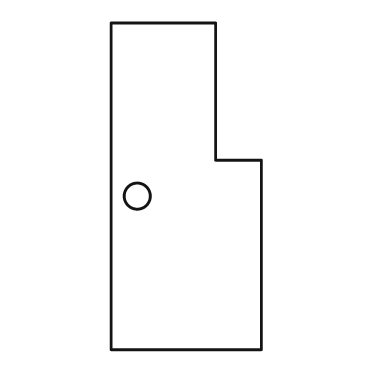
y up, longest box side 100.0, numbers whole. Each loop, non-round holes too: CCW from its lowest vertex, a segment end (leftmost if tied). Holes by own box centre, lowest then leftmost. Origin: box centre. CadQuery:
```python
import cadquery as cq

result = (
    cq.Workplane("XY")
    .moveTo(-23.0, -50.0)
    .lineTo(23.0, -50.0)
    .lineTo(23.0, 8.0)
    .lineTo(9.0, 8.0)
    .lineTo(9.0, 50.0)
    .lineTo(-23.0, 50.0)
    .close()
    .moveTo(-15.0, -3.0)
    .circle(4.0)
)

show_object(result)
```